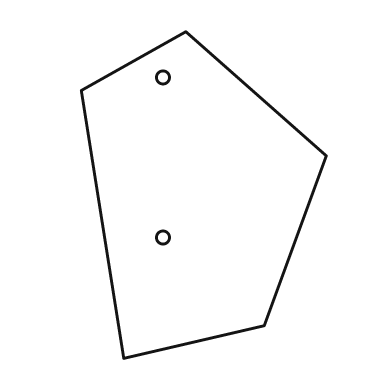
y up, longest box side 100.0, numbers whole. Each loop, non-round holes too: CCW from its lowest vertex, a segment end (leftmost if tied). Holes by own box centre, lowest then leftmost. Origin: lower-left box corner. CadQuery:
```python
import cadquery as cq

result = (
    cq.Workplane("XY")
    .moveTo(13.0, 0.0)
    .lineTo(56.0, 10.0)
    .lineTo(75.0, 62.0)
    .lineTo(32.0, 100.0)
    .lineTo(0.0, 82.0)
    .close()
    .moveTo(25.0, 37.0)
    .circle(2.0)
    .moveTo(25.0, 86.0)
    .circle(2.0)
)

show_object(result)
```